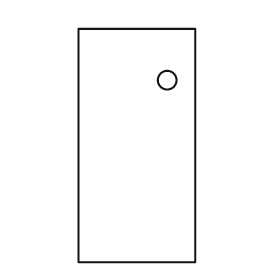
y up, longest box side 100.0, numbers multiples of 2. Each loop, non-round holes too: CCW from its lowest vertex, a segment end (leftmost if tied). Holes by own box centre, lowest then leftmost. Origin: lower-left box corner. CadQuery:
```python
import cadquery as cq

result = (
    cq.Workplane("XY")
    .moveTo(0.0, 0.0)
    .lineTo(50.0, 0.0)
    .lineTo(50.0, 100.0)
    .lineTo(0.0, 100.0)
    .close()
    .moveTo(38.0, 78.0)
    .circle(4.0)
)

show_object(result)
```